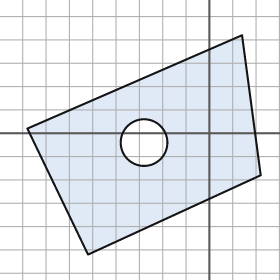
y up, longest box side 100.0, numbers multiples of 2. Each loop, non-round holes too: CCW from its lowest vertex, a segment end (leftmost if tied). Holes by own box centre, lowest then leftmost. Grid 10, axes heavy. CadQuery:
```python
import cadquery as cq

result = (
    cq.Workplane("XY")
    .moveTo(-52.0, -52.0)
    .lineTo(22.0, -18.0)
    .lineTo(14.0, 42.0)
    .lineTo(-78.0, 2.0)
    .close()
    .moveTo(-28.0, -4.0)
    .circle(10.0)
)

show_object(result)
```